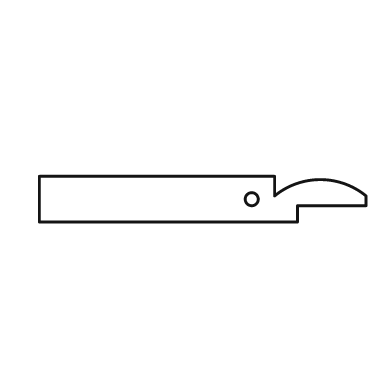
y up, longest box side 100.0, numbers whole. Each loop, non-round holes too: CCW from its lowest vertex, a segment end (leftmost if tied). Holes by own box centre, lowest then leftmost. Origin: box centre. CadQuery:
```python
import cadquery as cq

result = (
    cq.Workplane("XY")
    .moveTo(-50.0, -7.0)
    .lineTo(29.0, -7.0)
    .lineTo(29.0, -2.0)
    .lineTo(50.0, -2.0)
    .lineTo(50.0, 1.0)
    .threePointArc((36.0, 6.0), (22.0, 1.0))
    .lineTo(22.0, 7.0)
    .lineTo(-50.0, 7.0)
    .close()
    .moveTo(15.0, 0.0)
    .circle(2.0)
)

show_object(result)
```